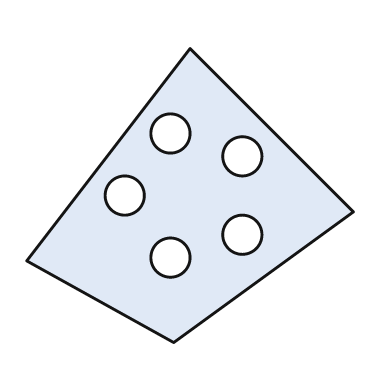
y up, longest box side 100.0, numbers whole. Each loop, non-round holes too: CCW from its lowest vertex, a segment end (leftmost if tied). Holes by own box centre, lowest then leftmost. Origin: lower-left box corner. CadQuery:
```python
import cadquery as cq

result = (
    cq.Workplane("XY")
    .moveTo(45.0, 0.0)
    .lineTo(100.0, 40.0)
    .lineTo(50.0, 90.0)
    .lineTo(0.0, 25.0)
    .close()
    .moveTo(44.0, 26.0)
    .circle(6.0)
    .moveTo(66.0, 33.0)
    .circle(6.0)
    .moveTo(30.0, 45.0)
    .circle(6.0)
    .moveTo(66.0, 57.0)
    .circle(6.0)
    .moveTo(44.0, 64.0)
    .circle(6.0)
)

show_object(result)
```